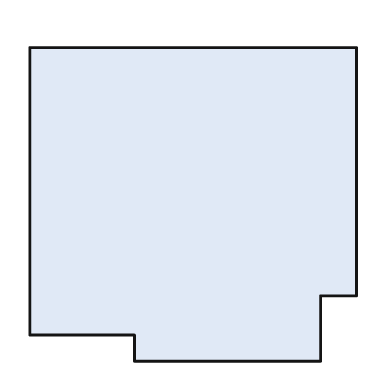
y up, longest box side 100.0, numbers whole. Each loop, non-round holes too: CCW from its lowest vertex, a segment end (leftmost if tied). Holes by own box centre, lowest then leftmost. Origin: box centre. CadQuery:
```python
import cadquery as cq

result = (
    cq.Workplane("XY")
    .moveTo(-18.0, -48.0)
    .lineTo(39.0, -48.0)
    .lineTo(39.0, -28.0)
    .lineTo(50.0, -28.0)
    .lineTo(50.0, 48.0)
    .lineTo(-50.0, 48.0)
    .lineTo(-50.0, -40.0)
    .lineTo(-18.0, -40.0)
    .close()
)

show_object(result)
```